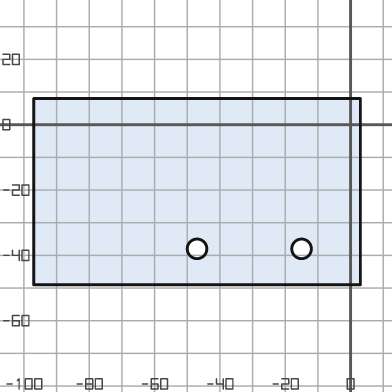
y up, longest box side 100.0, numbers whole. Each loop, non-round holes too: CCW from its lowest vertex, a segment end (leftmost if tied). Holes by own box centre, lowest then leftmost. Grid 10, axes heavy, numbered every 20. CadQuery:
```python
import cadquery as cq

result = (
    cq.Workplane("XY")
    .moveTo(-97.0, -49.0)
    .lineTo(3.0, -49.0)
    .lineTo(3.0, 8.0)
    .lineTo(-97.0, 8.0)
    .close()
    .moveTo(-47.0, -38.0)
    .circle(3.0)
    .moveTo(-15.0, -38.0)
    .circle(3.0)
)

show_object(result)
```